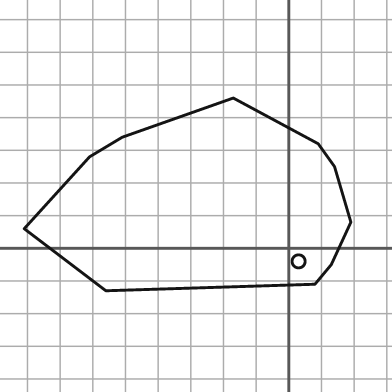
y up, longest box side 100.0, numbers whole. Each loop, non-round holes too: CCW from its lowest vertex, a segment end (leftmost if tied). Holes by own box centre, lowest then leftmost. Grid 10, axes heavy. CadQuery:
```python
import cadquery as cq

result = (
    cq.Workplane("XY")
    .moveTo(-56.0, -13.0)
    .lineTo(8.0, -11.0)
    .lineTo(13.0, -5.0)
    .lineTo(19.0, 8.0)
    .lineTo(14.0, 25.0)
    .lineTo(9.0, 32.0)
    .lineTo(-17.0, 46.0)
    .lineTo(-51.0, 34.0)
    .lineTo(-61.0, 28.0)
    .lineTo(-81.0, 6.0)
    .close()
    .moveTo(3.0, -4.0)
    .circle(2.0)
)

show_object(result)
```